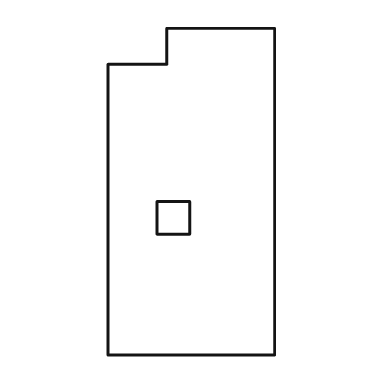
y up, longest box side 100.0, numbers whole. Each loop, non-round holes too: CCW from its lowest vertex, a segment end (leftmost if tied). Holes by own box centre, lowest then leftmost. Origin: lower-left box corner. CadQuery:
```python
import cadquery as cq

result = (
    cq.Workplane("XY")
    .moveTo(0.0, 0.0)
    .lineTo(51.0, 0.0)
    .lineTo(51.0, 100.0)
    .lineTo(18.0, 100.0)
    .lineTo(18.0, 89.0)
    .lineTo(0.0, 89.0)
    .close()
    .moveTo(15.0, 37.0)
    .lineTo(25.0, 37.0)
    .lineTo(25.0, 47.0)
    .lineTo(15.0, 47.0)
    .close()
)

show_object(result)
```